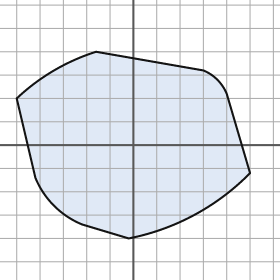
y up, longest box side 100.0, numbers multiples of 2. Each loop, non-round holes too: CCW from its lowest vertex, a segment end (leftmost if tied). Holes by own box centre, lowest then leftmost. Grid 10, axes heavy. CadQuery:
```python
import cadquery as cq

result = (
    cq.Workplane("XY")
    .moveTo(-2.0, -40.0)
    .threePointArc((26.0, -30.0), (50.0, -12.0))
    .lineTo(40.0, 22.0)
    .threePointArc((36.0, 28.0), (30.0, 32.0))
    .lineTo(-16.0, 40.0)
    .threePointArc((-34.0, 32.0), (-50.0, 20.0))
    .lineTo(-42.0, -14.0)
    .threePointArc((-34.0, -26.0), (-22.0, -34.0))
    .close()
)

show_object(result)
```